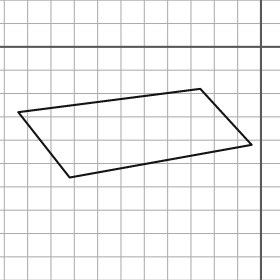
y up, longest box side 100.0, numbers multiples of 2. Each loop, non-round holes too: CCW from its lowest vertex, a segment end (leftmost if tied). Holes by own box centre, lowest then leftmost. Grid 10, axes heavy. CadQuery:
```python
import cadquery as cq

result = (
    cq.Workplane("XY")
    .moveTo(-82.0, -56.0)
    .lineTo(-4.0, -42.0)
    .lineTo(-26.0, -18.0)
    .lineTo(-104.0, -28.0)
    .close()
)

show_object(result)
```